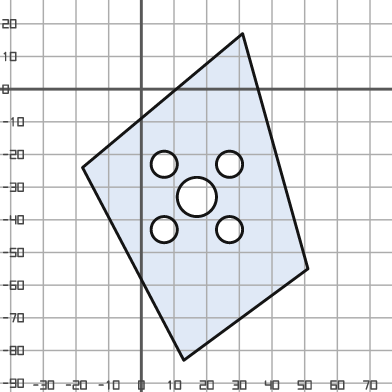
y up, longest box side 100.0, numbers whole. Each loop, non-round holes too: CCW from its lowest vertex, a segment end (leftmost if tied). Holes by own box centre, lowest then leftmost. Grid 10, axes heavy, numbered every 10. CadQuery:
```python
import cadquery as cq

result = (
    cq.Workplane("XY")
    .moveTo(13.0, -83.0)
    .lineTo(51.0, -55.0)
    .lineTo(31.0, 17.0)
    .lineTo(-18.0, -24.0)
    .close()
    .moveTo(7.0, -43.0)
    .circle(4.0)
    .moveTo(27.0, -43.0)
    .circle(4.0)
    .moveTo(17.0, -33.0)
    .circle(6.0)
    .moveTo(7.0, -23.0)
    .circle(4.0)
    .moveTo(27.0, -23.0)
    .circle(4.0)
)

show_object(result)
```